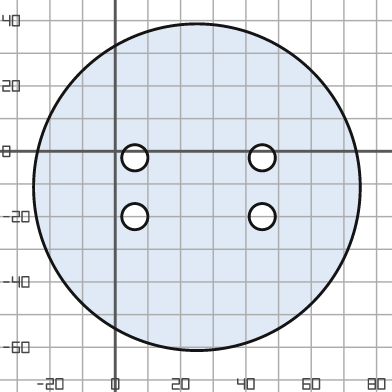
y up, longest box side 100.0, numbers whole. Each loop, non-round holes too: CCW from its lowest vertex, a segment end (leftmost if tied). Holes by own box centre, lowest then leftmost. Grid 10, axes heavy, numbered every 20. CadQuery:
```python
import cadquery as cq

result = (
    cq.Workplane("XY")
    .moveTo(25.0, -11.0)
    .circle(50.0)
    .moveTo(6.0, -20.0)
    .circle(4.0)
    .moveTo(45.0, -20.0)
    .circle(4.0)
    .moveTo(6.0, -2.0)
    .circle(4.0)
    .moveTo(45.0, -2.0)
    .circle(4.0)
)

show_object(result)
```